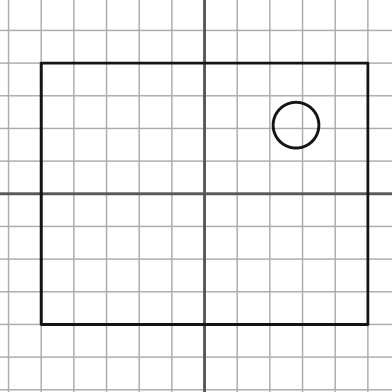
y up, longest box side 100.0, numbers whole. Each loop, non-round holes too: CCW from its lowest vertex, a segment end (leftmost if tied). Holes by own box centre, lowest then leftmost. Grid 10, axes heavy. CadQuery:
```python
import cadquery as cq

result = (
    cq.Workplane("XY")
    .moveTo(-50.0, -40.0)
    .lineTo(50.0, -40.0)
    .lineTo(50.0, 40.0)
    .lineTo(-50.0, 40.0)
    .close()
    .moveTo(28.0, 21.0)
    .circle(7.0)
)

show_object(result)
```